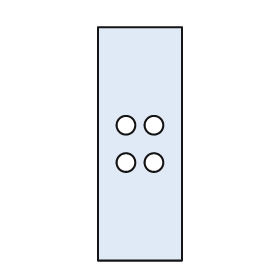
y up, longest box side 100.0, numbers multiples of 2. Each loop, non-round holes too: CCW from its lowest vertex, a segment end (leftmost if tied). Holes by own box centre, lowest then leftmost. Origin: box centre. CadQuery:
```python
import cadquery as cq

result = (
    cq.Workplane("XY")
    .moveTo(-18.0, -50.0)
    .lineTo(18.0, -50.0)
    .lineTo(18.0, 50.0)
    .lineTo(-18.0, 50.0)
    .close()
    .moveTo(-6.0, -8.0)
    .circle(4.0)
    .moveTo(6.0, -8.0)
    .circle(4.0)
    .moveTo(-6.0, 8.0)
    .circle(4.0)
    .moveTo(6.0, 8.0)
    .circle(4.0)
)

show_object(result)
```